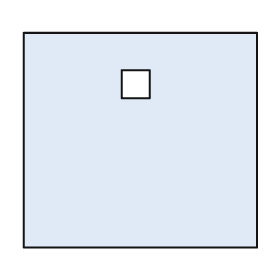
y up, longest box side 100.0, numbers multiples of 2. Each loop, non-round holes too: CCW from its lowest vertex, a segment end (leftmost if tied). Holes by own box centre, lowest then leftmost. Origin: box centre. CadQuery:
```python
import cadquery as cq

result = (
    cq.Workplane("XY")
    .moveTo(-50.0, -46.0)
    .lineTo(50.0, -46.0)
    .lineTo(50.0, 46.0)
    .lineTo(-50.0, 46.0)
    .close()
    .moveTo(-8.0, 18.0)
    .lineTo(4.0, 18.0)
    .lineTo(4.0, 30.0)
    .lineTo(-8.0, 30.0)
    .close()
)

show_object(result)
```